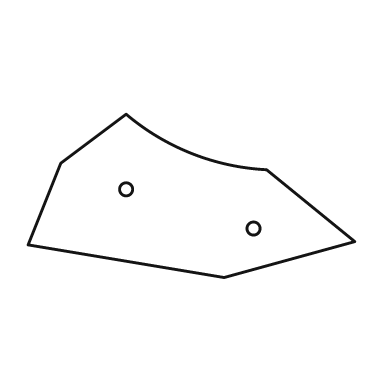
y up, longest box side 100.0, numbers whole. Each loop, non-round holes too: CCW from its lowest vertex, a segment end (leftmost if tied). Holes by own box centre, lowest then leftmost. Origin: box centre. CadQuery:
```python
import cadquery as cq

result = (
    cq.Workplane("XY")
    .moveTo(10.0, -25.0)
    .lineTo(50.0, -14.0)
    .lineTo(23.0, 8.0)
    .threePointArc((0.0, 13.0), (-20.0, 25.0))
    .lineTo(-40.0, 10.0)
    .lineTo(-50.0, -15.0)
    .close()
    .moveTo(19.0, -10.0)
    .circle(2.0)
    .moveTo(-20.0, 2.0)
    .circle(2.0)
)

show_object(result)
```